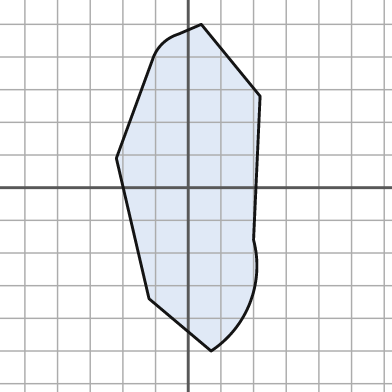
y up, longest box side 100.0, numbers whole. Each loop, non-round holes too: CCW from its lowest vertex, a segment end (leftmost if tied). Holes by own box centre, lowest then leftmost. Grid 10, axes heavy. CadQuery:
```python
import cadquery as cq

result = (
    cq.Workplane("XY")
    .moveTo(7.0, -50.0)
    .threePointArc((19.0, -35.0), (20.0, -16.0))
    .lineTo(22.0, 28.0)
    .lineTo(4.0, 50.0)
    .lineTo(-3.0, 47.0)
    .threePointArc((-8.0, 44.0), (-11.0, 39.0))
    .lineTo(-22.0, 9.0)
    .lineTo(-12.0, -34.0)
    .close()
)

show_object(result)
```